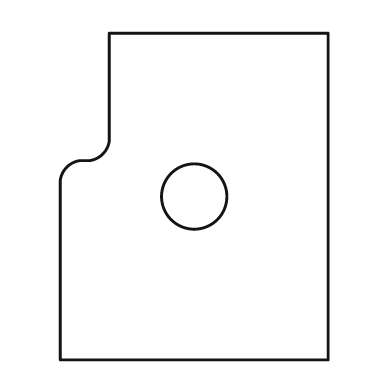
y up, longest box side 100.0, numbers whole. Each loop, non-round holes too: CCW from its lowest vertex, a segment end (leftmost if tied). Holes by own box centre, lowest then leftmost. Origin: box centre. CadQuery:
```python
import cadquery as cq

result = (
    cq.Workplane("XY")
    .moveTo(-41.0, -50.0)
    .lineTo(41.0, -50.0)
    .lineTo(41.0, 50.0)
    .lineTo(-26.0, 50.0)
    .lineTo(-26.0, 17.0)
    .threePointArc((-28.0, 13.0), (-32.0, 11.0))
    .lineTo(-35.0, 11.0)
    .threePointArc((-39.0, 9.0), (-41.0, 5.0))
    .close()
    .moveTo(0.0, 0.0)
    .circle(10.0)
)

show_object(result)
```